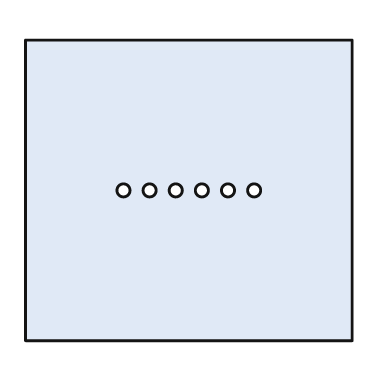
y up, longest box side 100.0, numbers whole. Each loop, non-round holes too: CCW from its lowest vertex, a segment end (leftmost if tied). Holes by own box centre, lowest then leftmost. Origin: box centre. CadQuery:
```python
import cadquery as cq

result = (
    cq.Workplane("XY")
    .moveTo(-50.0, -46.0)
    .lineTo(50.0, -46.0)
    .lineTo(50.0, 46.0)
    .lineTo(-50.0, 46.0)
    .close()
    .moveTo(-20.0, 0.0)
    .circle(2.0)
    .moveTo(-12.0, 0.0)
    .circle(2.0)
    .moveTo(-4.0, 0.0)
    .circle(2.0)
    .moveTo(4.0, 0.0)
    .circle(2.0)
    .moveTo(12.0, 0.0)
    .circle(2.0)
    .moveTo(20.0, 0.0)
    .circle(2.0)
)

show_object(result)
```